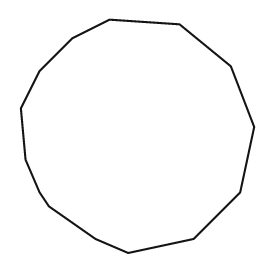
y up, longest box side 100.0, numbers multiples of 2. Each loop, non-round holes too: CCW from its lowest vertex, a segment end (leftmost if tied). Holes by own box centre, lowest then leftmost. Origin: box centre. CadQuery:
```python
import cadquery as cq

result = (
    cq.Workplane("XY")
    .moveTo(-4.0, -50.0)
    .lineTo(24.0, -44.0)
    .lineTo(44.0, -24.0)
    .lineTo(50.0, 4.0)
    .lineTo(40.0, 30.0)
    .lineTo(18.0, 48.0)
    .lineTo(-12.0, 50.0)
    .lineTo(-28.0, 42.0)
    .lineTo(-42.0, 28.0)
    .lineTo(-50.0, 12.0)
    .lineTo(-48.0, -10.0)
    .lineTo(-42.0, -24.0)
    .lineTo(-38.0, -30.0)
    .lineTo(-18.0, -44.0)
    .close()
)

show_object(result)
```